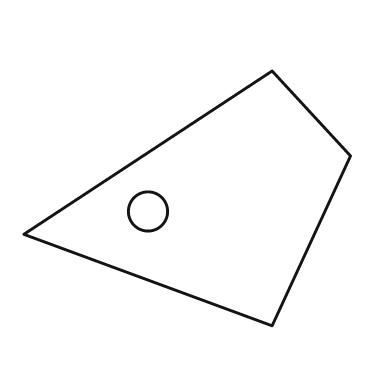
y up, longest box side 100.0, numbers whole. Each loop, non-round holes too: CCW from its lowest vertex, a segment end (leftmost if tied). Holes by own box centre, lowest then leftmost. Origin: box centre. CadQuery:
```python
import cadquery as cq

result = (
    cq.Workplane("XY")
    .moveTo(26.0, -39.0)
    .lineTo(50.0, 13.0)
    .lineTo(26.0, 39.0)
    .lineTo(-50.0, -11.0)
    .close()
    .moveTo(-12.0, -4.0)
    .circle(6.0)
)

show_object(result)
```